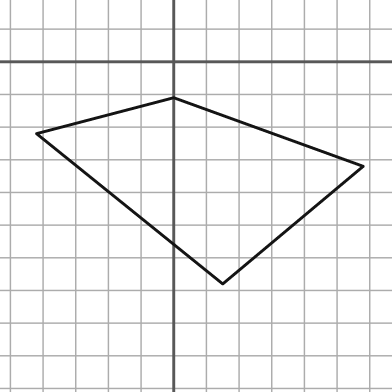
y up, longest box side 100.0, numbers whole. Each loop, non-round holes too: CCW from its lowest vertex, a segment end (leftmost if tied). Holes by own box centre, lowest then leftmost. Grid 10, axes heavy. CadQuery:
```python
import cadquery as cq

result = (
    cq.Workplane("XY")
    .moveTo(15.0, -68.0)
    .lineTo(58.0, -32.0)
    .lineTo(0.0, -11.0)
    .lineTo(-42.0, -22.0)
    .close()
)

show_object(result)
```